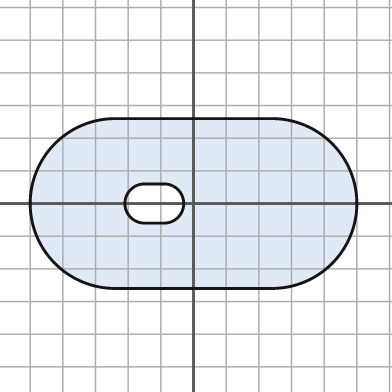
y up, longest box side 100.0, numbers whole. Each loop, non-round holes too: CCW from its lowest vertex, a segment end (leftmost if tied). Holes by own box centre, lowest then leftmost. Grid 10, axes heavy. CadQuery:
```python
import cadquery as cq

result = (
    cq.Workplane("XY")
    .moveTo(-24.0, -26.0)
    .lineTo(24.0, -26.0)
    .threePointArc((50.0, 0.0), (24.0, 26.0))
    .lineTo(-24.0, 26.0)
    .threePointArc((-50.0, 0.0), (-24.0, -26.0))
    .close()
    .moveTo(-15.0, -6.0)
    .lineTo(-9.0, -6.0)
    .threePointArc((-3.0, 0.0), (-9.0, 6.0))
    .lineTo(-15.0, 6.0)
    .threePointArc((-21.0, 0.0), (-15.0, -6.0))
    .close()
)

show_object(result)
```